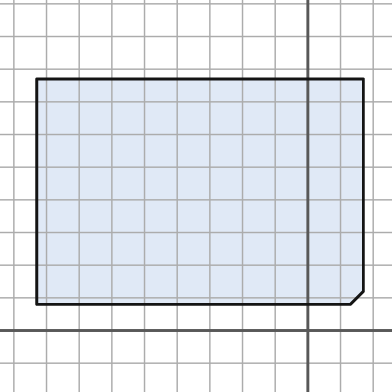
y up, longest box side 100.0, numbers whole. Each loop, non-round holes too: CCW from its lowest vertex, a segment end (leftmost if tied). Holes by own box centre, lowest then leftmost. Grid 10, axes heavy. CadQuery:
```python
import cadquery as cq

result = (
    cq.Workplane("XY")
    .moveTo(-83.0, 8.0)
    .lineTo(13.0, 8.0)
    .lineTo(17.0, 12.0)
    .lineTo(17.0, 77.0)
    .lineTo(-83.0, 77.0)
    .close()
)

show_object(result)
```